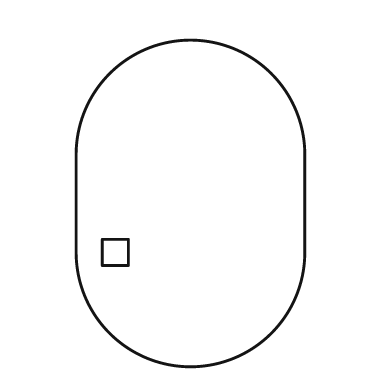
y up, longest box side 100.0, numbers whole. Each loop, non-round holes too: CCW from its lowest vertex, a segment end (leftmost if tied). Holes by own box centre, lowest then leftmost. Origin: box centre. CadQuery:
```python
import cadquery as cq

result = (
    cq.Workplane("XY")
    .moveTo(-35.0, -15.0)
    .threePointArc((0.0, -50.0), (35.0, -15.0))
    .lineTo(35.0, 15.0)
    .threePointArc((0.0, 50.0), (-35.0, 15.0))
    .close()
    .moveTo(-27.0, -19.0)
    .lineTo(-19.0, -19.0)
    .lineTo(-19.0, -11.0)
    .lineTo(-27.0, -11.0)
    .close()
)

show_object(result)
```